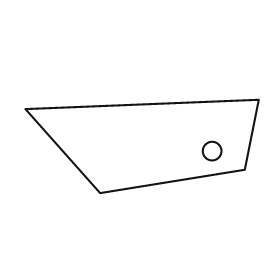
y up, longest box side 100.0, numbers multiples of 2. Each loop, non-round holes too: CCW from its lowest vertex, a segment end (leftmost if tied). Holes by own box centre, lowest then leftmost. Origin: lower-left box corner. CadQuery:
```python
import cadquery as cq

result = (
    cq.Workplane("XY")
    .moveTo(32.0, 0.0)
    .lineTo(94.0, 10.0)
    .lineTo(100.0, 40.0)
    .lineTo(0.0, 36.0)
    .close()
    .moveTo(80.0, 18.0)
    .circle(4.0)
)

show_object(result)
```